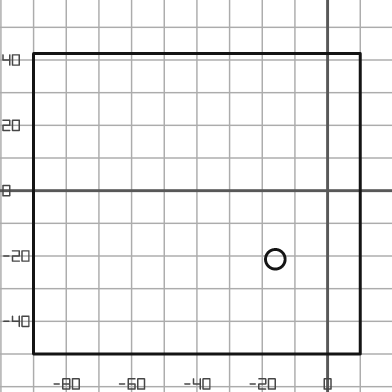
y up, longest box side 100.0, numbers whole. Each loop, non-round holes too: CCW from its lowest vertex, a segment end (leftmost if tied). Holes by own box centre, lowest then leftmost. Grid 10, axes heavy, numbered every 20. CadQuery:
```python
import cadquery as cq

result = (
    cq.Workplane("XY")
    .moveTo(-90.0, -50.0)
    .lineTo(10.0, -50.0)
    .lineTo(10.0, 42.0)
    .lineTo(-90.0, 42.0)
    .close()
    .moveTo(-16.0, -21.0)
    .circle(3.0)
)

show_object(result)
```